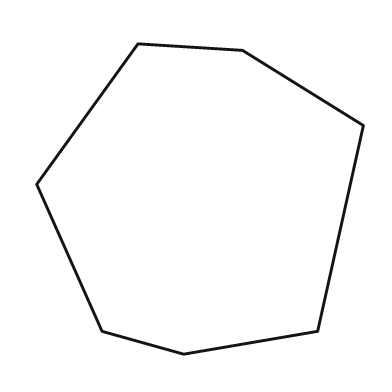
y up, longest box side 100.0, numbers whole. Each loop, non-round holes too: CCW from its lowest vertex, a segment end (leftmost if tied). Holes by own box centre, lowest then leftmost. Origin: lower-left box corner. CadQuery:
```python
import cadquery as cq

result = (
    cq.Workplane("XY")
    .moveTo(45.0, 0.0)
    .lineTo(86.0, 7.0)
    .lineTo(100.0, 70.0)
    .lineTo(63.0, 93.0)
    .lineTo(31.0, 95.0)
    .lineTo(0.0, 52.0)
    .lineTo(20.0, 7.0)
    .close()
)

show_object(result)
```